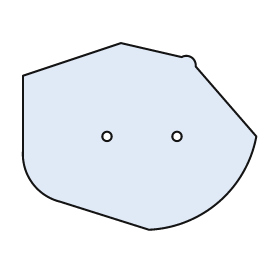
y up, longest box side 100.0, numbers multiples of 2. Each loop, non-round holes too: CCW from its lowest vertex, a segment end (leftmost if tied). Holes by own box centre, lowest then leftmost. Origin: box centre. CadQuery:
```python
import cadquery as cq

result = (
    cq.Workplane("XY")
    .moveTo(4.0, -40.0)
    .threePointArc((34.0, -28.0), (50.0, 0.0))
    .lineTo(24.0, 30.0)
    .threePointArc((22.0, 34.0), (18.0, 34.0))
    .lineTo(-8.0, 40.0)
    .lineTo(-50.0, 26.0)
    .lineTo(-50.0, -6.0)
    .threePointArc((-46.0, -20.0), (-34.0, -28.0))
    .close()
    .moveTo(-14.0, 0.0)
    .circle(2.0)
    .moveTo(16.0, 0.0)
    .circle(2.0)
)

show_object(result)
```